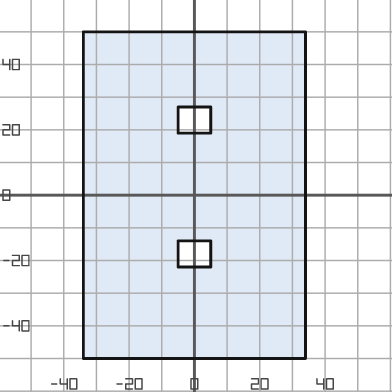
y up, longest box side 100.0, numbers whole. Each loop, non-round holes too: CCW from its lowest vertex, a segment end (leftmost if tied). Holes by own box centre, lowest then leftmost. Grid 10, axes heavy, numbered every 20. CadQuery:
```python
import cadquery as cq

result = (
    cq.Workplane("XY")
    .moveTo(-34.0, -50.0)
    .lineTo(34.0, -50.0)
    .lineTo(34.0, 50.0)
    .lineTo(-34.0, 50.0)
    .close()
    .moveTo(-5.0, -22.0)
    .lineTo(5.0, -22.0)
    .lineTo(5.0, -14.0)
    .lineTo(-5.0, -14.0)
    .close()
    .moveTo(-5.0, 19.0)
    .lineTo(5.0, 19.0)
    .lineTo(5.0, 27.0)
    .lineTo(-5.0, 27.0)
    .close()
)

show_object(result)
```